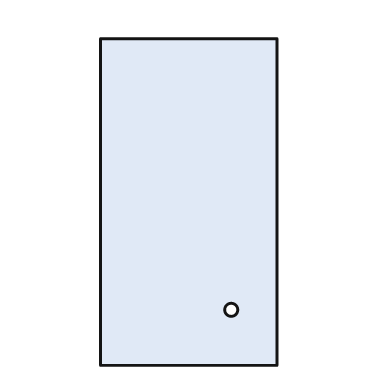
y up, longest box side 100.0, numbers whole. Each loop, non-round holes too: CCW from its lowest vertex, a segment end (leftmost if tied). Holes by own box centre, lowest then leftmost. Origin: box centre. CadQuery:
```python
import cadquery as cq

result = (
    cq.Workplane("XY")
    .moveTo(-27.0, -50.0)
    .lineTo(27.0, -50.0)
    .lineTo(27.0, 50.0)
    .lineTo(-27.0, 50.0)
    .close()
    .moveTo(13.0, -33.0)
    .circle(2.0)
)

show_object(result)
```